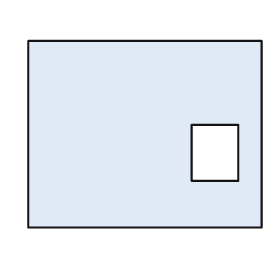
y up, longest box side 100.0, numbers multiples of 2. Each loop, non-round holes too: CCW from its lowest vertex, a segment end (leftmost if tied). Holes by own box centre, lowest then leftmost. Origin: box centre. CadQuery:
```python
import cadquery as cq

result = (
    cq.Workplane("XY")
    .moveTo(-50.0, -40.0)
    .lineTo(50.0, -40.0)
    .lineTo(50.0, 40.0)
    .lineTo(-50.0, 40.0)
    .close()
    .moveTo(20.0, -20.0)
    .lineTo(40.0, -20.0)
    .lineTo(40.0, 4.0)
    .lineTo(20.0, 4.0)
    .close()
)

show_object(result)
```